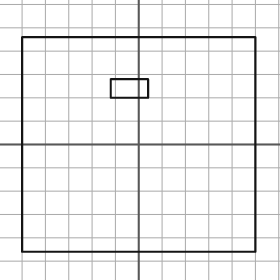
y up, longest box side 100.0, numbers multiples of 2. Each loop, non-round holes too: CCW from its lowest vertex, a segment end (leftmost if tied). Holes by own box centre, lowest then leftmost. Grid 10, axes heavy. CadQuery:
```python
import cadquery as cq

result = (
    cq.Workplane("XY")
    .moveTo(-50.0, -46.0)
    .lineTo(50.0, -46.0)
    .lineTo(50.0, 46.0)
    .lineTo(-50.0, 46.0)
    .close()
    .moveTo(-12.0, 20.0)
    .lineTo(4.0, 20.0)
    .lineTo(4.0, 28.0)
    .lineTo(-12.0, 28.0)
    .close()
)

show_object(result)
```